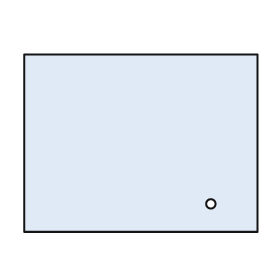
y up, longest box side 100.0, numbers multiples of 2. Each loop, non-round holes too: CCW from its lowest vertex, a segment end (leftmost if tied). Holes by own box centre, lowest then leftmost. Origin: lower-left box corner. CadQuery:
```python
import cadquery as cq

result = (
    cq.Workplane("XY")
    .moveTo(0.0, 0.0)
    .lineTo(100.0, 0.0)
    .lineTo(100.0, 76.0)
    .lineTo(0.0, 76.0)
    .close()
    .moveTo(80.0, 12.0)
    .circle(2.0)
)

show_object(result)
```